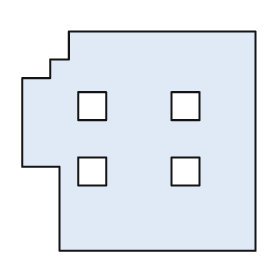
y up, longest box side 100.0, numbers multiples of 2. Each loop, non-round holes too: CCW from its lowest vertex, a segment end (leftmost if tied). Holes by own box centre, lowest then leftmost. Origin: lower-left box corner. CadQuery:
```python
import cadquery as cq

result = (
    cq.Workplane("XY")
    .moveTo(16.0, 0.0)
    .lineTo(100.0, 0.0)
    .lineTo(100.0, 94.0)
    .lineTo(20.0, 94.0)
    .lineTo(20.0, 82.0)
    .lineTo(12.0, 82.0)
    .lineTo(12.0, 74.0)
    .lineTo(0.0, 74.0)
    .lineTo(0.0, 36.0)
    .lineTo(16.0, 36.0)
    .close()
    .moveTo(24.0, 28.0)
    .lineTo(36.0, 28.0)
    .lineTo(36.0, 40.0)
    .lineTo(24.0, 40.0)
    .close()
    .moveTo(64.0, 28.0)
    .lineTo(76.0, 28.0)
    .lineTo(76.0, 40.0)
    .lineTo(64.0, 40.0)
    .close()
    .moveTo(24.0, 56.0)
    .lineTo(36.0, 56.0)
    .lineTo(36.0, 68.0)
    .lineTo(24.0, 68.0)
    .close()
    .moveTo(64.0, 56.0)
    .lineTo(76.0, 56.0)
    .lineTo(76.0, 68.0)
    .lineTo(64.0, 68.0)
    .close()
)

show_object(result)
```